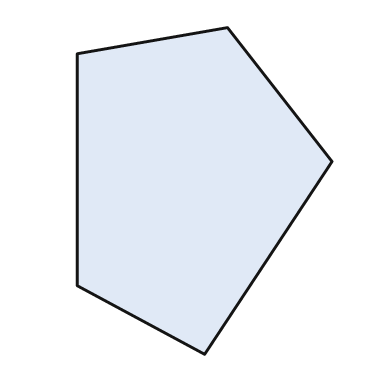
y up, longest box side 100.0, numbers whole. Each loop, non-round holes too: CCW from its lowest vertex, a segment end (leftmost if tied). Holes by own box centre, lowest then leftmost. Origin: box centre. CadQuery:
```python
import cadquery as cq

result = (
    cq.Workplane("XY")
    .moveTo(0.0, -50.0)
    .lineTo(39.0, 9.0)
    .lineTo(7.0, 50.0)
    .lineTo(-39.0, 42.0)
    .lineTo(-39.0, -29.0)
    .close()
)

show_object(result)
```